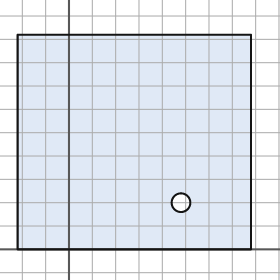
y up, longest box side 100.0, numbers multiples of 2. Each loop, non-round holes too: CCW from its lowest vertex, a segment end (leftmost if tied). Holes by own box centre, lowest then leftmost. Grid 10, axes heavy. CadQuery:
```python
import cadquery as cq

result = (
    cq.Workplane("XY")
    .moveTo(-22.0, 0.0)
    .lineTo(78.0, 0.0)
    .lineTo(78.0, 92.0)
    .lineTo(-22.0, 92.0)
    .close()
    .moveTo(48.0, 20.0)
    .circle(4.0)
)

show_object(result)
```